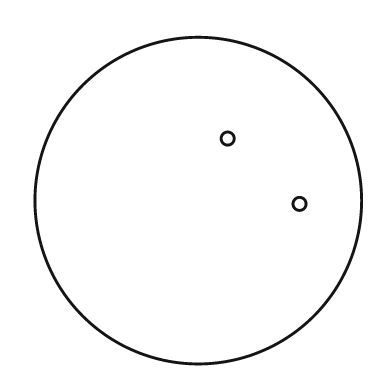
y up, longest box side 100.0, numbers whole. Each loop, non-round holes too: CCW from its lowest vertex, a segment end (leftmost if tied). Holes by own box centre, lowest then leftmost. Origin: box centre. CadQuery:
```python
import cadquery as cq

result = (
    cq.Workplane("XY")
    .moveTo(0.0, 0.0)
    .circle(50.0)
    .moveTo(31.0, -1.0)
    .circle(2.0)
    .moveTo(9.0, 19.0)
    .circle(2.0)
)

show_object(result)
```